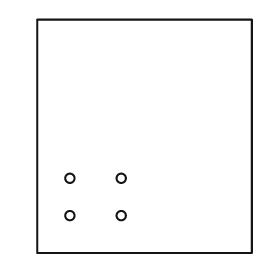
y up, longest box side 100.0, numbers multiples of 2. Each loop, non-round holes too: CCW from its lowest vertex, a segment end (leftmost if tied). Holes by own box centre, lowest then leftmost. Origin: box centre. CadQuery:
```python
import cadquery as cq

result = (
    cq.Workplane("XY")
    .moveTo(-46.0, -50.0)
    .lineTo(46.0, -50.0)
    .lineTo(46.0, 50.0)
    .lineTo(-46.0, 50.0)
    .close()
    .moveTo(-32.0, -34.0)
    .circle(2.0)
    .moveTo(-10.0, -34.0)
    .circle(2.0)
    .moveTo(-32.0, -18.0)
    .circle(2.0)
    .moveTo(-10.0, -18.0)
    .circle(2.0)
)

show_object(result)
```